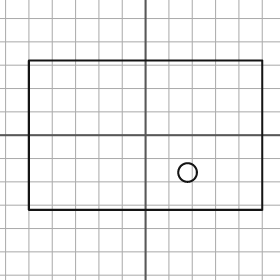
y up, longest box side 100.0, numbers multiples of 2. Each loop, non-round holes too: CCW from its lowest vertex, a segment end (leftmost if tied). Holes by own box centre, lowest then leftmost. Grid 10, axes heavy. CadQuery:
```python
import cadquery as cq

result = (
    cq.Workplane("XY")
    .moveTo(-50.0, -32.0)
    .lineTo(50.0, -32.0)
    .lineTo(50.0, 32.0)
    .lineTo(-50.0, 32.0)
    .close()
    .moveTo(18.0, -16.0)
    .circle(4.0)
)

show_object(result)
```